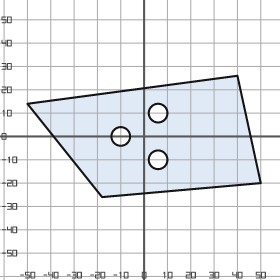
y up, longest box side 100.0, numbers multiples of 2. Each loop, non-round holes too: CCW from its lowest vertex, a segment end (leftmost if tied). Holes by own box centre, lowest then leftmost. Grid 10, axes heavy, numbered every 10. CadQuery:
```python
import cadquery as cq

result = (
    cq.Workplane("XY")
    .moveTo(-18.0, -26.0)
    .lineTo(50.0, -20.0)
    .lineTo(40.0, 26.0)
    .lineTo(-50.0, 14.0)
    .close()
    .moveTo(6.0, -10.0)
    .circle(4.0)
    .moveTo(-10.0, 0.0)
    .circle(4.0)
    .moveTo(6.0, 10.0)
    .circle(4.0)
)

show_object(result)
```